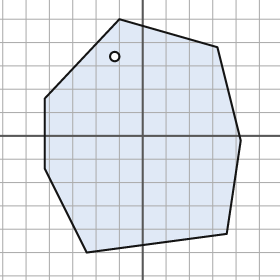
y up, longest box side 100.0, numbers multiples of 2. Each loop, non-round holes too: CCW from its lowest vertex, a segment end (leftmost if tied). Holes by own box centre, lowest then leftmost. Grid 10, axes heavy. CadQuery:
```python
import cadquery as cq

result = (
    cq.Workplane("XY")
    .moveTo(-24.0, -50.0)
    .lineTo(36.0, -42.0)
    .lineTo(42.0, -2.0)
    .lineTo(32.0, 38.0)
    .lineTo(-10.0, 50.0)
    .lineTo(-42.0, 16.0)
    .lineTo(-42.0, -14.0)
    .close()
    .moveTo(-12.0, 34.0)
    .circle(2.0)
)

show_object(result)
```